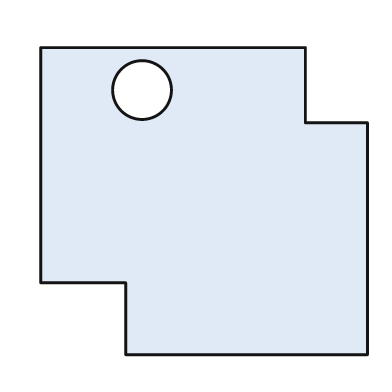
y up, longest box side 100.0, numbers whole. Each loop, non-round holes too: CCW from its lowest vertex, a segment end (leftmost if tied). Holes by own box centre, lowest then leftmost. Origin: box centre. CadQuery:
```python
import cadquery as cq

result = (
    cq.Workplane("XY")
    .moveTo(-24.0, -47.0)
    .lineTo(50.0, -47.0)
    .lineTo(50.0, 24.0)
    .lineTo(31.0, 24.0)
    .lineTo(31.0, 47.0)
    .lineTo(-50.0, 47.0)
    .lineTo(-50.0, -25.0)
    .lineTo(-24.0, -25.0)
    .close()
    .moveTo(-19.0, 34.0)
    .circle(9.0)
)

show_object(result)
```